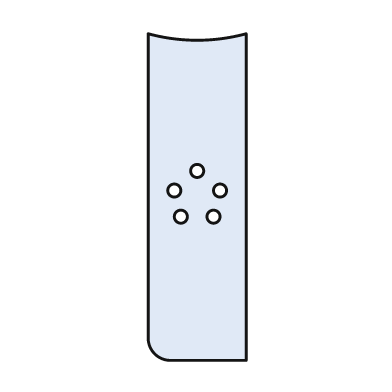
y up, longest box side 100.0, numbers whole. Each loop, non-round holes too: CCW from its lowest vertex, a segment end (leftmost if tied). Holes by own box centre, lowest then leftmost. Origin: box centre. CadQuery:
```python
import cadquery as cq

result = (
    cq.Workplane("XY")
    .moveTo(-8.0, -50.0)
    .lineTo(15.0, -50.0)
    .lineTo(15.0, 50.0)
    .threePointArc((0.0, 48.0), (-15.0, 50.0))
    .lineTo(-15.0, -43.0)
    .threePointArc((-13.0, -48.0), (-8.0, -50.0))
    .close()
    .moveTo(-5.0, -6.0)
    .circle(2.0)
    .moveTo(5.0, -6.0)
    .circle(2.0)
    .moveTo(-7.0, 2.0)
    .circle(2.0)
    .moveTo(7.0, 2.0)
    .circle(2.0)
    .moveTo(0.0, 8.0)
    .circle(2.0)
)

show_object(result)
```